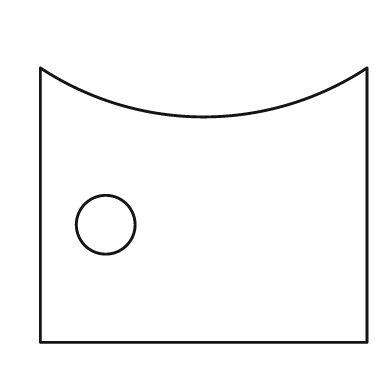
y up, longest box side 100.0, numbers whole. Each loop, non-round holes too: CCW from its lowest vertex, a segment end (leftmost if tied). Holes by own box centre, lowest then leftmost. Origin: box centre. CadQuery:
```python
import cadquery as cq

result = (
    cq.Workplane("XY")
    .moveTo(-50.0, -42.0)
    .lineTo(50.0, -42.0)
    .lineTo(50.0, 42.0)
    .threePointArc((0.0, 27.0), (-50.0, 42.0))
    .close()
    .moveTo(-30.0, -6.0)
    .circle(9.0)
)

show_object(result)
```